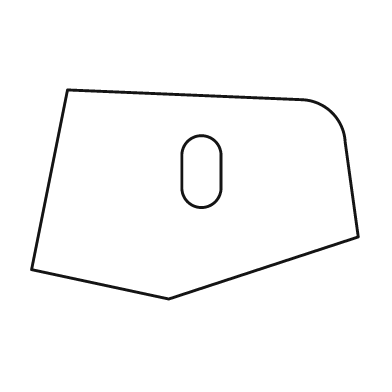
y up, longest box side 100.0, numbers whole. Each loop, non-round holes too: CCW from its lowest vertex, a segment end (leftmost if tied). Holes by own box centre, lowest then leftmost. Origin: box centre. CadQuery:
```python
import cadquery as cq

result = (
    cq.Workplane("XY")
    .moveTo(-8.0, -32.0)
    .lineTo(50.0, -13.0)
    .lineTo(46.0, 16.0)
    .threePointArc((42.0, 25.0), (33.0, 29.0))
    .lineTo(-39.0, 32.0)
    .lineTo(-50.0, -23.0)
    .close()
    .moveTo(-4.0, 2.0)
    .threePointArc((2.0, -4.0), (8.0, 2.0))
    .lineTo(8.0, 12.0)
    .threePointArc((2.0, 18.0), (-4.0, 12.0))
    .close()
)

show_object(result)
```